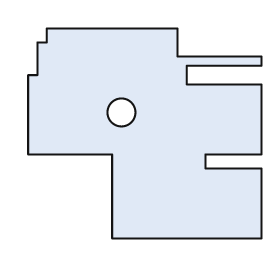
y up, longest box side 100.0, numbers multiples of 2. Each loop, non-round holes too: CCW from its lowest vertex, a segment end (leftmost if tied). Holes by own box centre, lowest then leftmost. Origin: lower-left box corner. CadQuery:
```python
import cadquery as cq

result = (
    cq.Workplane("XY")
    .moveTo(36.0, 0.0)
    .lineTo(100.0, 0.0)
    .lineTo(100.0, 30.0)
    .lineTo(76.0, 30.0)
    .lineTo(76.0, 36.0)
    .lineTo(100.0, 36.0)
    .lineTo(100.0, 66.0)
    .lineTo(68.0, 66.0)
    .lineTo(68.0, 74.0)
    .lineTo(100.0, 74.0)
    .lineTo(100.0, 78.0)
    .lineTo(64.0, 78.0)
    .lineTo(64.0, 90.0)
    .lineTo(8.0, 90.0)
    .lineTo(8.0, 84.0)
    .lineTo(4.0, 84.0)
    .lineTo(4.0, 70.0)
    .lineTo(0.0, 70.0)
    .lineTo(0.0, 36.0)
    .lineTo(36.0, 36.0)
    .close()
    .moveTo(40.0, 54.0)
    .circle(6.0)
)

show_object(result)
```